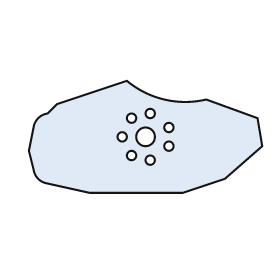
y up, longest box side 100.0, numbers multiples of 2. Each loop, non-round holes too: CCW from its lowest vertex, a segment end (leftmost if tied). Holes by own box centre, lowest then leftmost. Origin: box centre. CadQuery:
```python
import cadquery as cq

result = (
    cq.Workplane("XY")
    .moveTo(-24.0, -24.0)
    .lineTo(16.0, -24.0)
    .lineTo(34.0, -18.0)
    .lineTo(50.0, -4.0)
    .lineTo(48.0, 8.0)
    .lineTo(26.0, 16.0)
    .threePointArc((8.0, 16.0), (-8.0, 24.0))
    .lineTo(-38.0, 14.0)
    .lineTo(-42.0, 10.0)
    .threePointArc((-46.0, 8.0), (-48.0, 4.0))
    .lineTo(-50.0, -6.0)
    .lineTo(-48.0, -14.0)
    .threePointArc((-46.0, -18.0), (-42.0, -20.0))
    .close()
    .moveTo(2.0, -10.0)
    .circle(2.0)
    .moveTo(-6.0, -8.0)
    .circle(2.0)
    .moveTo(10.0, -4.0)
    .circle(2.0)
    .moveTo(-10.0, 0.0)
    .circle(2.0)
    .moveTo(0.0, 0.0)
    .circle(4.0)
    .moveTo(10.0, 4.0)
    .circle(2.0)
    .moveTo(-6.0, 8.0)
    .circle(2.0)
    .moveTo(2.0, 10.0)
    .circle(2.0)
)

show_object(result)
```